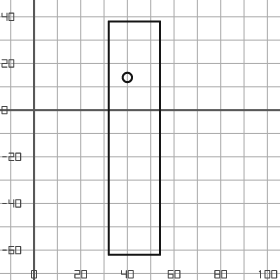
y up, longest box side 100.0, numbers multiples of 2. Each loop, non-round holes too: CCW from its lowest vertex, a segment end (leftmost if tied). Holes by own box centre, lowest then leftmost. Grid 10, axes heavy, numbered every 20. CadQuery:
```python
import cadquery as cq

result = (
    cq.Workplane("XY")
    .moveTo(32.0, -62.0)
    .lineTo(54.0, -62.0)
    .lineTo(54.0, 38.0)
    .lineTo(32.0, 38.0)
    .close()
    .moveTo(40.0, 14.0)
    .circle(2.0)
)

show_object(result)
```